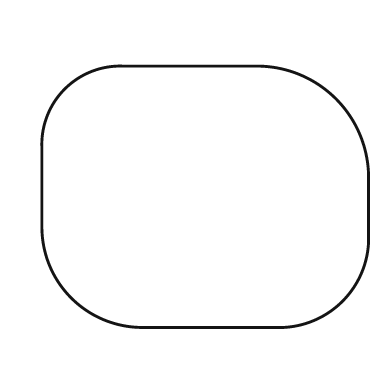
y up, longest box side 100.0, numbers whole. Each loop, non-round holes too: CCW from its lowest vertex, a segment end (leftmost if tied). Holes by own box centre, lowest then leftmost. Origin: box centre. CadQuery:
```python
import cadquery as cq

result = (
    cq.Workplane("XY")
    .moveTo(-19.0, -40.0)
    .lineTo(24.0, -40.0)
    .threePointArc((42.0, -32.0), (50.0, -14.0))
    .lineTo(50.0, 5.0)
    .threePointArc((40.0, 30.0), (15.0, 40.0))
    .lineTo(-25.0, 40.0)
    .threePointArc((-43.0, 33.0), (-50.0, 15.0))
    .lineTo(-50.0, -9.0)
    .threePointArc((-41.0, -31.0), (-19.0, -40.0))
    .close()
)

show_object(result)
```